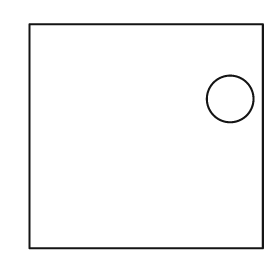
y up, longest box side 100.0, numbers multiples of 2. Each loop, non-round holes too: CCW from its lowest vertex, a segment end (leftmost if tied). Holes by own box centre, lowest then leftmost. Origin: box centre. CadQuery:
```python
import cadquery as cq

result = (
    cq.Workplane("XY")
    .moveTo(-50.0, -48.0)
    .lineTo(50.0, -48.0)
    .lineTo(50.0, 48.0)
    .lineTo(-50.0, 48.0)
    .close()
    .moveTo(36.0, 16.0)
    .circle(10.0)
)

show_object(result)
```